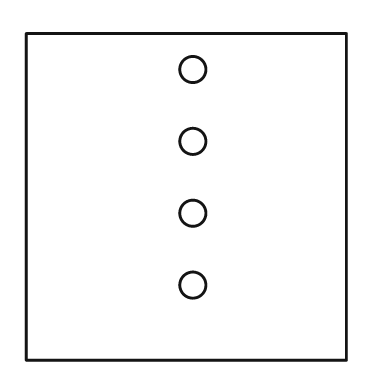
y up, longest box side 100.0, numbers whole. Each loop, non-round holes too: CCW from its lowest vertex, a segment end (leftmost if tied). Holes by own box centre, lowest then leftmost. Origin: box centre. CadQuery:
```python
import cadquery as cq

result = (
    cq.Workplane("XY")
    .moveTo(-49.0, -50.0)
    .lineTo(49.0, -50.0)
    .lineTo(49.0, 50.0)
    .lineTo(-49.0, 50.0)
    .close()
    .moveTo(2.0, -27.0)
    .circle(4.0)
    .moveTo(2.0, -5.0)
    .circle(4.0)
    .moveTo(2.0, 17.0)
    .circle(4.0)
    .moveTo(2.0, 39.0)
    .circle(4.0)
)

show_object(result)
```